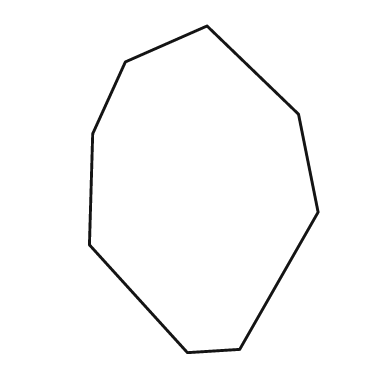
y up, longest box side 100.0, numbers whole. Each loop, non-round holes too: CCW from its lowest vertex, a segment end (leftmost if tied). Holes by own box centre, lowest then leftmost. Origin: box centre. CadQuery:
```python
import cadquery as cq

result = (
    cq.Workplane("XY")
    .moveTo(-5.0, -50.0)
    .lineTo(11.0, -49.0)
    .lineTo(35.0, -7.0)
    .lineTo(29.0, 23.0)
    .lineTo(1.0, 50.0)
    .lineTo(-24.0, 39.0)
    .lineTo(-34.0, 17.0)
    .lineTo(-35.0, -17.0)
    .close()
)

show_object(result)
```